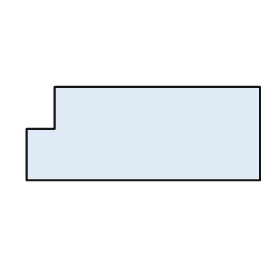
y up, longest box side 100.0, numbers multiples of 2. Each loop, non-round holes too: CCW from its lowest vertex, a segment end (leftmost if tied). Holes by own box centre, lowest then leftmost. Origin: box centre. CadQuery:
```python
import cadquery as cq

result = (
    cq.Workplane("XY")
    .moveTo(-50.0, -20.0)
    .lineTo(50.0, -20.0)
    .lineTo(50.0, 20.0)
    .lineTo(-38.0, 20.0)
    .lineTo(-38.0, 2.0)
    .lineTo(-50.0, 2.0)
    .close()
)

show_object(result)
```